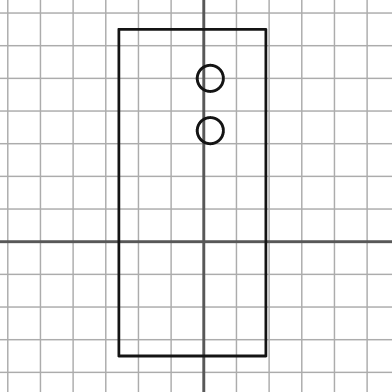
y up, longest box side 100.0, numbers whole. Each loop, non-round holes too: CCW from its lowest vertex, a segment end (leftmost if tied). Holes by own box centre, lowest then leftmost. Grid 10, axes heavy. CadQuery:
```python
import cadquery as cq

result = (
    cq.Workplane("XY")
    .moveTo(-26.0, -35.0)
    .lineTo(19.0, -35.0)
    .lineTo(19.0, 65.0)
    .lineTo(-26.0, 65.0)
    .close()
    .moveTo(2.0, 34.0)
    .circle(4.0)
    .moveTo(2.0, 50.0)
    .circle(4.0)
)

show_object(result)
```